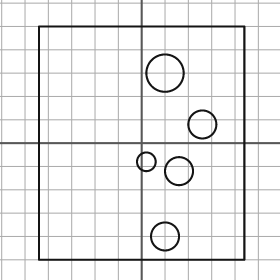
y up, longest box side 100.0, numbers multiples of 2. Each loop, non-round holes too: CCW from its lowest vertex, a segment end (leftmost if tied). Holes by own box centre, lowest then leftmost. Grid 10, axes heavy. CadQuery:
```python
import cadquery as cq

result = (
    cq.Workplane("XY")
    .moveTo(-44.0, -50.0)
    .lineTo(44.0, -50.0)
    .lineTo(44.0, 50.0)
    .lineTo(-44.0, 50.0)
    .close()
    .moveTo(10.0, -40.0)
    .circle(6.0)
    .moveTo(16.0, -12.0)
    .circle(6.0)
    .moveTo(2.0, -8.0)
    .circle(4.0)
    .moveTo(26.0, 8.0)
    .circle(6.0)
    .moveTo(10.0, 30.0)
    .circle(8.0)
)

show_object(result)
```